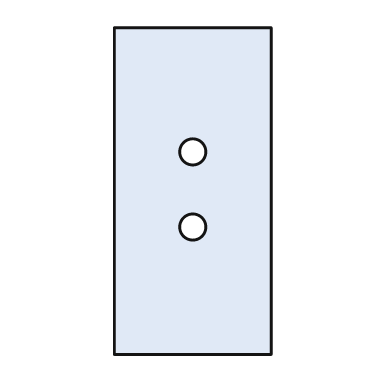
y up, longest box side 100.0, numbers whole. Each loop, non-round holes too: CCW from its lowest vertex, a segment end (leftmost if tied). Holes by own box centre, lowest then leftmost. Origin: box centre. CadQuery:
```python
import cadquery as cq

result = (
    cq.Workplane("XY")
    .moveTo(-24.0, -50.0)
    .lineTo(24.0, -50.0)
    .lineTo(24.0, 50.0)
    .lineTo(-24.0, 50.0)
    .close()
    .moveTo(0.0, -11.0)
    .circle(4.0)
    .moveTo(0.0, 12.0)
    .circle(4.0)
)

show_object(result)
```